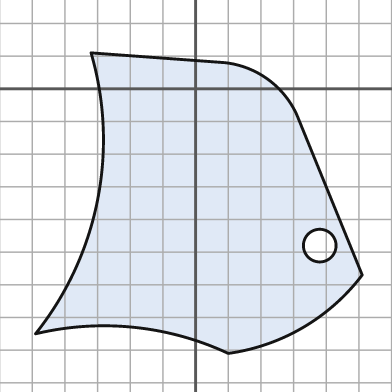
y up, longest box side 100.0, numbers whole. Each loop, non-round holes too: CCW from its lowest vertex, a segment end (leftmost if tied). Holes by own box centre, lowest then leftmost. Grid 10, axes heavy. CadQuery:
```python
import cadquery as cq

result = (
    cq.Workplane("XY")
    .moveTo(10.0, -81.0)
    .threePointArc((33.0, -73.0), (51.0, -57.0))
    .lineTo(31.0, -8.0)
    .threePointArc((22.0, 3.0), (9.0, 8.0))
    .lineTo(-32.0, 11.0)
    .threePointArc((-30.0, -34.0), (-49.0, -75.0))
    .threePointArc((-19.0, -73.0), (10.0, -81.0))
    .close()
    .moveTo(38.0, -48.0)
    .circle(5.0)
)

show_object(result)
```